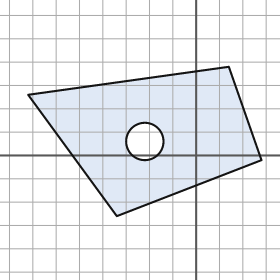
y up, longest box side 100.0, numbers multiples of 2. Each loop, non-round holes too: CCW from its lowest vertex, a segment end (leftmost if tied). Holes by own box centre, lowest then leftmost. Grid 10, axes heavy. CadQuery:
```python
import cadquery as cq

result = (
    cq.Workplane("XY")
    .moveTo(-34.0, -26.0)
    .lineTo(28.0, -2.0)
    .lineTo(14.0, 38.0)
    .lineTo(-72.0, 26.0)
    .close()
    .moveTo(-22.0, 6.0)
    .circle(8.0)
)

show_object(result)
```